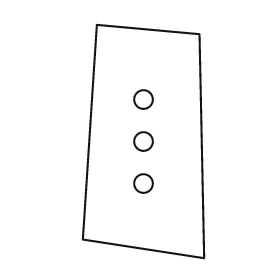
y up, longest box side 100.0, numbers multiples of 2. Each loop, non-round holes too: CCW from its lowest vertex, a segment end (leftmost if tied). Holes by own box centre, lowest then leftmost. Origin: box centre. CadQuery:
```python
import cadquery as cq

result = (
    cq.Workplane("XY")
    .moveTo(26.0, -50.0)
    .lineTo(24.0, 46.0)
    .lineTo(-20.0, 50.0)
    .lineTo(-26.0, -42.0)
    .close()
    .moveTo(0.0, -18.0)
    .circle(4.0)
    .moveTo(0.0, 0.0)
    .circle(4.0)
    .moveTo(0.0, 18.0)
    .circle(4.0)
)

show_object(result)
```